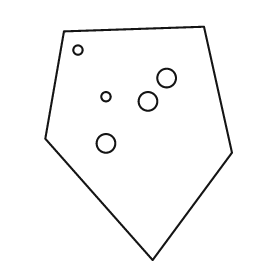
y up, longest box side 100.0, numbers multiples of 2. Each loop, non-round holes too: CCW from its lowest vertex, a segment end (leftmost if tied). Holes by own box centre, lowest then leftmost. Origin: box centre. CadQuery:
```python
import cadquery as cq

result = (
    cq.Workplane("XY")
    .moveTo(6.0, -50.0)
    .lineTo(40.0, -4.0)
    .lineTo(28.0, 50.0)
    .lineTo(-32.0, 48.0)
    .lineTo(-40.0, 2.0)
    .close()
    .moveTo(-14.0, 0.0)
    .circle(4.0)
    .moveTo(4.0, 18.0)
    .circle(4.0)
    .moveTo(-14.0, 20.0)
    .circle(2.0)
    .moveTo(12.0, 28.0)
    .circle(4.0)
    .moveTo(-26.0, 40.0)
    .circle(2.0)
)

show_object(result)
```